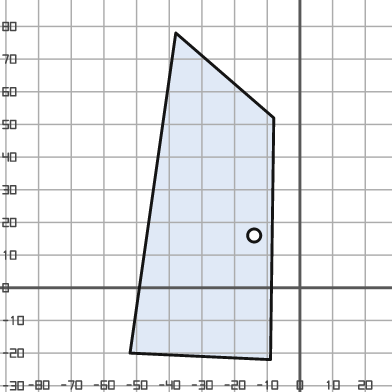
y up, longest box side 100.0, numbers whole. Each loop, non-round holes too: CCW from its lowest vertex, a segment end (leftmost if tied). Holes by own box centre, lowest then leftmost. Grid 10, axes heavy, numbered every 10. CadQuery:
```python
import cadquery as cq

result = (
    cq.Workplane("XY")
    .moveTo(-9.0, -22.0)
    .lineTo(-8.0, 52.0)
    .lineTo(-38.0, 78.0)
    .lineTo(-52.0, -20.0)
    .close()
    .moveTo(-14.0, 16.0)
    .circle(2.0)
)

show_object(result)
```